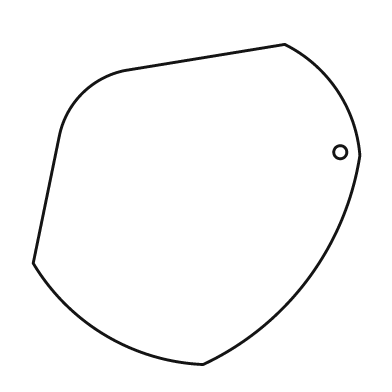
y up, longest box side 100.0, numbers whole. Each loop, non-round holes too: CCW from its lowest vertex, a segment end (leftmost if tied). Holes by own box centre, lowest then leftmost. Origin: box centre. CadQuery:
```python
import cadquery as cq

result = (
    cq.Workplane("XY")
    .moveTo(2.0, -49.0)
    .threePointArc((34.0, -23.0), (50.0, 15.0))
    .threePointArc((43.0, 35.0), (27.0, 49.0))
    .lineTo(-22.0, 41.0)
    .threePointArc((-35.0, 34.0), (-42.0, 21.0))
    .lineTo(-50.0, -18.0)
    .threePointArc((-28.0, -40.0), (2.0, -49.0))
    .close()
    .moveTo(44.0, 16.0)
    .circle(2.0)
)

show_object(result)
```